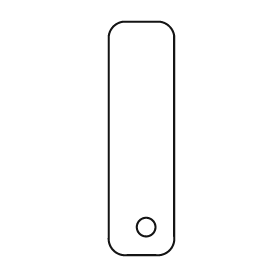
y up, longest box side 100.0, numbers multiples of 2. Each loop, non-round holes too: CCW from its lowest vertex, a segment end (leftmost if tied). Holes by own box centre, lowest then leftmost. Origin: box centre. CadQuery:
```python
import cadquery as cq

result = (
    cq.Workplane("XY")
    .moveTo(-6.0, -50.0)
    .lineTo(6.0, -50.0)
    .threePointArc((12.0, -48.0), (14.0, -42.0))
    .lineTo(14.0, 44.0)
    .threePointArc((12.0, 48.0), (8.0, 50.0))
    .lineTo(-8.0, 50.0)
    .threePointArc((-12.0, 48.0), (-14.0, 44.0))
    .lineTo(-14.0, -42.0)
    .threePointArc((-12.0, -48.0), (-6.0, -50.0))
    .close()
    .moveTo(2.0, -38.0)
    .circle(4.0)
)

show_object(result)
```